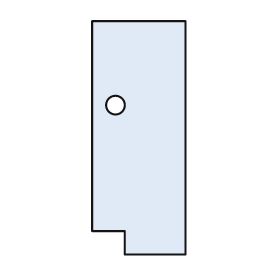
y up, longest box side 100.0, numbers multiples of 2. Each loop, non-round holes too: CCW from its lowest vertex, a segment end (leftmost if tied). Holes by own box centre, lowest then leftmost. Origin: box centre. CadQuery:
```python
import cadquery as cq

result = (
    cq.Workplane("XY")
    .moveTo(-6.0, -50.0)
    .lineTo(20.0, -50.0)
    .lineTo(20.0, 50.0)
    .lineTo(-20.0, 50.0)
    .lineTo(-20.0, -40.0)
    .lineTo(-6.0, -40.0)
    .close()
    .moveTo(-10.0, 14.0)
    .circle(4.0)
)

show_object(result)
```